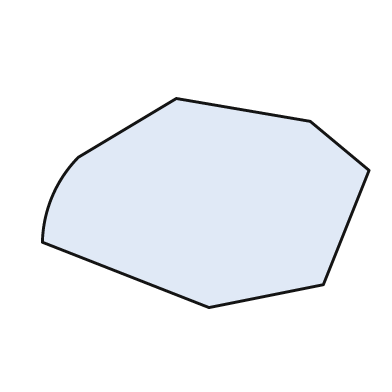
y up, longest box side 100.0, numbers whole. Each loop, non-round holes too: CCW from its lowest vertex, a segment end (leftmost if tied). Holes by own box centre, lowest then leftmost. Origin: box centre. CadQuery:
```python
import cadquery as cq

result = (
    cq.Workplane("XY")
    .moveTo(1.0, -32.0)
    .lineTo(36.0, -25.0)
    .lineTo(50.0, 10.0)
    .lineTo(32.0, 25.0)
    .lineTo(-9.0, 32.0)
    .lineTo(-39.0, 14.0)
    .threePointArc((-47.0, 2.0), (-50.0, -12.0))
    .close()
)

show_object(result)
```